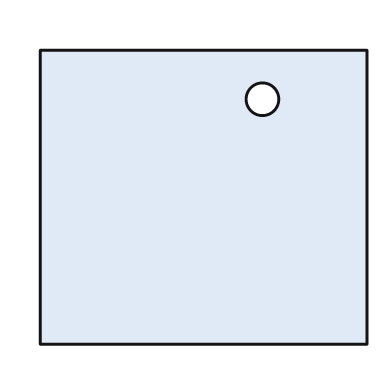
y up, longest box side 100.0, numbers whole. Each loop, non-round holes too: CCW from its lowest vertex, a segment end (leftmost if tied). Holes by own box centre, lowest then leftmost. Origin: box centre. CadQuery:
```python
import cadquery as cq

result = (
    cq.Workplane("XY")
    .moveTo(-50.0, -45.0)
    .lineTo(50.0, -45.0)
    .lineTo(50.0, 45.0)
    .lineTo(-50.0, 45.0)
    .close()
    .moveTo(18.0, 30.0)
    .circle(5.0)
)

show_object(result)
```